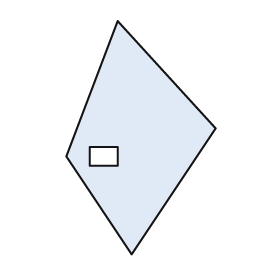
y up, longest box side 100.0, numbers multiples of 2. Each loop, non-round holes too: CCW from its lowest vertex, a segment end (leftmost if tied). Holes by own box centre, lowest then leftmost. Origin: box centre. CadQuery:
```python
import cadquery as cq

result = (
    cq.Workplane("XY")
    .moveTo(-4.0, -50.0)
    .lineTo(32.0, 4.0)
    .lineTo(-10.0, 50.0)
    .lineTo(-32.0, -8.0)
    .close()
    .moveTo(-22.0, -12.0)
    .lineTo(-10.0, -12.0)
    .lineTo(-10.0, -4.0)
    .lineTo(-22.0, -4.0)
    .close()
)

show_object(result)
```